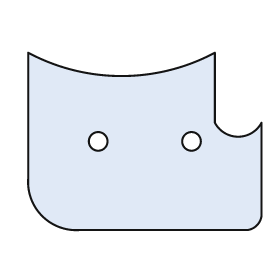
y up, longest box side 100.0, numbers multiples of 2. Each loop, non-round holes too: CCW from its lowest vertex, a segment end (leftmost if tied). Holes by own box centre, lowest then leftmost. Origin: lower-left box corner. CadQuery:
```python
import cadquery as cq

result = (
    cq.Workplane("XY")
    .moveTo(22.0, 0.0)
    .lineTo(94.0, 0.0)
    .threePointArc((98.0, 2.0), (100.0, 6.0))
    .lineTo(100.0, 46.0)
    .threePointArc((90.0, 40.0), (80.0, 46.0))
    .lineTo(80.0, 76.0)
    .threePointArc((40.0, 66.0), (0.0, 76.0))
    .lineTo(0.0, 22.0)
    .threePointArc((6.0, 6.0), (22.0, 0.0))
    .close()
    .moveTo(30.0, 38.0)
    .circle(4.0)
    .moveTo(70.0, 38.0)
    .circle(4.0)
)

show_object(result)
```